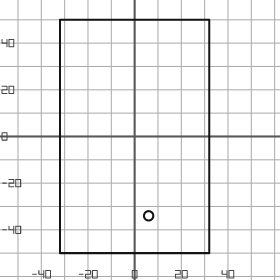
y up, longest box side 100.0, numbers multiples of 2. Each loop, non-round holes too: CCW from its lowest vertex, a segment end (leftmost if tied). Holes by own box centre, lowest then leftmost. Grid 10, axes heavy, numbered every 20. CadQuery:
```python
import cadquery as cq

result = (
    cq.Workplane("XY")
    .moveTo(-32.0, -50.0)
    .lineTo(32.0, -50.0)
    .lineTo(32.0, 50.0)
    .lineTo(-32.0, 50.0)
    .close()
    .moveTo(6.0, -34.0)
    .circle(2.0)
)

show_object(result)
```